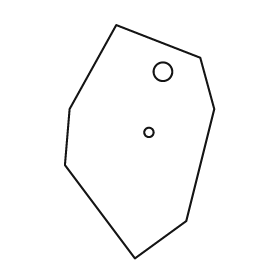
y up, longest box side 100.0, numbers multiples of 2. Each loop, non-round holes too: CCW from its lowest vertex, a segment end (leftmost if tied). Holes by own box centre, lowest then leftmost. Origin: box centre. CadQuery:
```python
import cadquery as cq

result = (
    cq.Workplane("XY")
    .moveTo(-2.0, -50.0)
    .lineTo(20.0, -34.0)
    .lineTo(32.0, 14.0)
    .lineTo(26.0, 36.0)
    .lineTo(-10.0, 50.0)
    .lineTo(-30.0, 14.0)
    .lineTo(-32.0, -10.0)
    .close()
    .moveTo(4.0, 4.0)
    .circle(2.0)
    .moveTo(10.0, 30.0)
    .circle(4.0)
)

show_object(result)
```